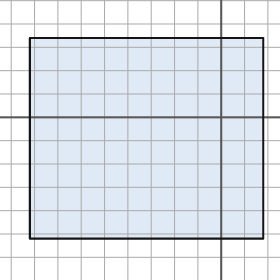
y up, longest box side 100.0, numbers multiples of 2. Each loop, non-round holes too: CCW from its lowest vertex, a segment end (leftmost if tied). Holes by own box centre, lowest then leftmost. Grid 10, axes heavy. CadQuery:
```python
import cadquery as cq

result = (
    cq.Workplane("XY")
    .moveTo(-82.0, -52.0)
    .lineTo(18.0, -52.0)
    .lineTo(18.0, 34.0)
    .lineTo(-82.0, 34.0)
    .close()
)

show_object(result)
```